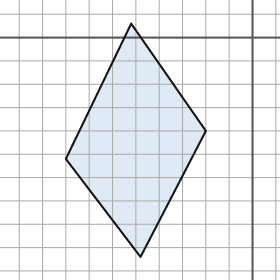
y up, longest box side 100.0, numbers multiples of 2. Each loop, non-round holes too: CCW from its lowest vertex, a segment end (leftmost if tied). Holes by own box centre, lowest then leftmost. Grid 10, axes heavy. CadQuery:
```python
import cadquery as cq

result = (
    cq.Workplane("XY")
    .moveTo(-48.0, -94.0)
    .lineTo(-20.0, -40.0)
    .lineTo(-52.0, 6.0)
    .lineTo(-80.0, -52.0)
    .close()
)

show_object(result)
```